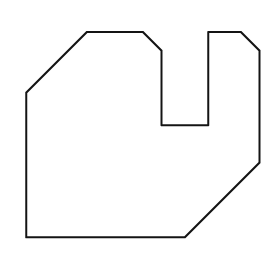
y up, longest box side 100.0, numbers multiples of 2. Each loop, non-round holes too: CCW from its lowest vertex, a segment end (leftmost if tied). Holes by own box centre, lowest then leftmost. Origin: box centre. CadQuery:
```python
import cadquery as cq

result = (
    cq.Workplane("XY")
    .moveTo(-50.0, -44.0)
    .lineTo(18.0, -44.0)
    .lineTo(50.0, -12.0)
    .lineTo(50.0, 36.0)
    .lineTo(42.0, 44.0)
    .lineTo(28.0, 44.0)
    .lineTo(28.0, 4.0)
    .lineTo(8.0, 4.0)
    .lineTo(8.0, 36.0)
    .lineTo(0.0, 44.0)
    .lineTo(-24.0, 44.0)
    .lineTo(-50.0, 18.0)
    .close()
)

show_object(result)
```